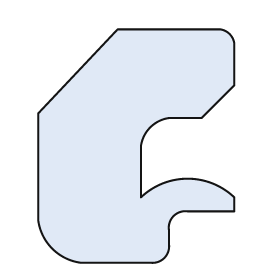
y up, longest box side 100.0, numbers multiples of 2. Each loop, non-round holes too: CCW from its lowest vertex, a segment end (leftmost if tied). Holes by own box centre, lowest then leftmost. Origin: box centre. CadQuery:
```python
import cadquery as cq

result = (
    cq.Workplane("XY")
    .moveTo(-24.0, -50.0)
    .lineTo(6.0, -50.0)
    .threePointArc((12.0, -48.0), (14.0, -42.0))
    .lineTo(14.0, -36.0)
    .threePointArc((16.0, -30.0), (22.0, -28.0))
    .lineTo(42.0, -28.0)
    .lineTo(42.0, -22.0)
    .threePointArc((22.0, -14.0), (2.0, -22.0))
    .lineTo(2.0, 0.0)
    .threePointArc((6.0, 8.0), (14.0, 12.0))
    .lineTo(28.0, 12.0)
    .lineTo(42.0, 26.0)
    .lineTo(42.0, 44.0)
    .threePointArc((40.0, 48.0), (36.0, 50.0))
    .lineTo(-8.0, 50.0)
    .lineTo(-42.0, 14.0)
    .lineTo(-42.0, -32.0)
    .threePointArc((-36.0, -44.0), (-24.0, -50.0))
    .close()
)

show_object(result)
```